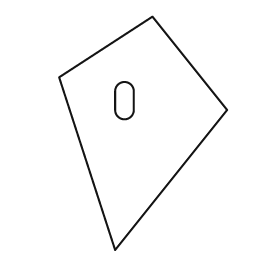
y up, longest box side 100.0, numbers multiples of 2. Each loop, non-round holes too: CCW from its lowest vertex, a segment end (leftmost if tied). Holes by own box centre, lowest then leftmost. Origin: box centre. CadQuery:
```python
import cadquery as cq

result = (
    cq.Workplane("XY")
    .moveTo(-12.0, -50.0)
    .lineTo(36.0, 10.0)
    .lineTo(4.0, 50.0)
    .lineTo(-36.0, 24.0)
    .close()
    .moveTo(-12.0, 10.0)
    .threePointArc((-8.0, 6.0), (-4.0, 10.0))
    .lineTo(-4.0, 18.0)
    .threePointArc((-8.0, 22.0), (-12.0, 18.0))
    .close()
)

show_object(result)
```